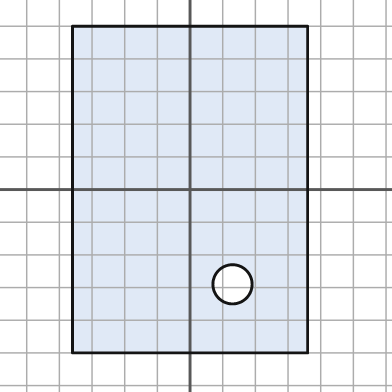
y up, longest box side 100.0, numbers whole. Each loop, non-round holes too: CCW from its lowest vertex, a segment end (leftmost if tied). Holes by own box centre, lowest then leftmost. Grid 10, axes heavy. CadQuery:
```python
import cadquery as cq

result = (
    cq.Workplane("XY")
    .moveTo(-36.0, -50.0)
    .lineTo(36.0, -50.0)
    .lineTo(36.0, 50.0)
    .lineTo(-36.0, 50.0)
    .close()
    .moveTo(13.0, -29.0)
    .circle(6.0)
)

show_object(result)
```